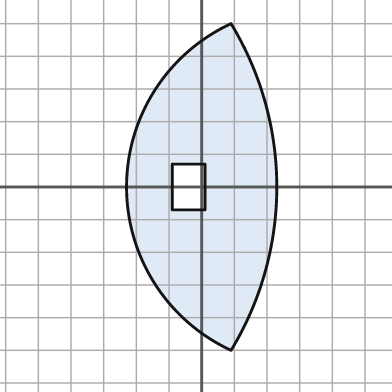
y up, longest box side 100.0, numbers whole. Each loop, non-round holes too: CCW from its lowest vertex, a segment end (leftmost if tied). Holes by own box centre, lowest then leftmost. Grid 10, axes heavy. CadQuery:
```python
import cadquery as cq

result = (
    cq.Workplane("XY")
    .moveTo(9.0, -50.0)
    .threePointArc((23.0, 0.0), (9.0, 50.0))
    .threePointArc((-23.0, 0.0), (9.0, -50.0))
    .close()
    .moveTo(-9.0, -7.0)
    .lineTo(1.0, -7.0)
    .lineTo(1.0, 7.0)
    .lineTo(-9.0, 7.0)
    .close()
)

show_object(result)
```